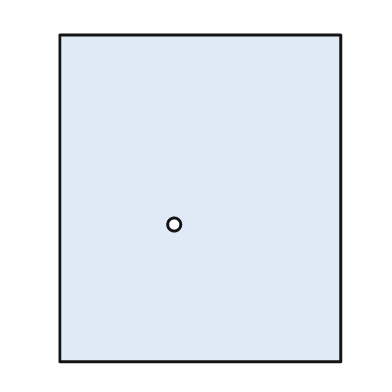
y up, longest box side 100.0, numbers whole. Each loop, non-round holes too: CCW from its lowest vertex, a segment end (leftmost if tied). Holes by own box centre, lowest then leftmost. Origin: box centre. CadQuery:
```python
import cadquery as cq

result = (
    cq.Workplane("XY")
    .moveTo(-43.0, -50.0)
    .lineTo(43.0, -50.0)
    .lineTo(43.0, 50.0)
    .lineTo(-43.0, 50.0)
    .close()
    .moveTo(-8.0, -8.0)
    .circle(2.0)
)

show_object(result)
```